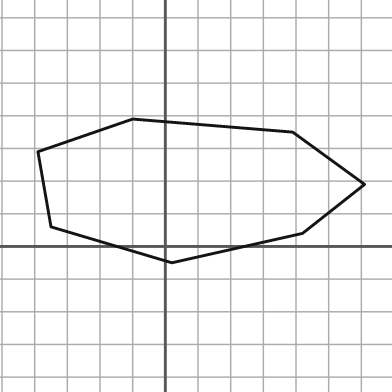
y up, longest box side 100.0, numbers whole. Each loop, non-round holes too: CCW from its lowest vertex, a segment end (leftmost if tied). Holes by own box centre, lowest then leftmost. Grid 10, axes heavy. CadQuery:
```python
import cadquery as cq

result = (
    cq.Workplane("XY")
    .moveTo(2.0, -5.0)
    .lineTo(42.0, 4.0)
    .lineTo(61.0, 19.0)
    .lineTo(39.0, 35.0)
    .lineTo(-10.0, 39.0)
    .lineTo(-39.0, 29.0)
    .lineTo(-35.0, 6.0)
    .close()
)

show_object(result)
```